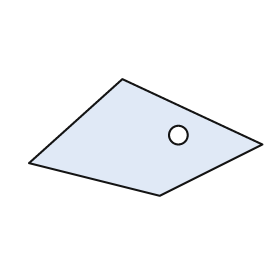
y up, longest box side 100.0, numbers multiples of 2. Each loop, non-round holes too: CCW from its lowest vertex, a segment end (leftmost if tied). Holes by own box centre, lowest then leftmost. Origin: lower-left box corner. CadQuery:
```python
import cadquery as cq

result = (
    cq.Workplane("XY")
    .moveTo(56.0, 0.0)
    .lineTo(100.0, 22.0)
    .lineTo(40.0, 50.0)
    .lineTo(0.0, 14.0)
    .close()
    .moveTo(64.0, 26.0)
    .circle(4.0)
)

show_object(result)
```